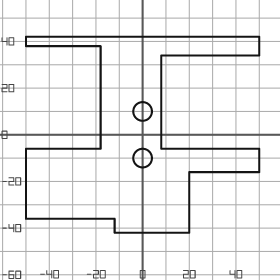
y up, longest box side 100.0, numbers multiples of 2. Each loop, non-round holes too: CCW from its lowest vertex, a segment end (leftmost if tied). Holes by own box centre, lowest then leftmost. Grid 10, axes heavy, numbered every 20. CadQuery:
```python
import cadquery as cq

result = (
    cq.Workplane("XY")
    .moveTo(-12.0, -42.0)
    .lineTo(20.0, -42.0)
    .lineTo(20.0, -16.0)
    .lineTo(50.0, -16.0)
    .lineTo(50.0, -6.0)
    .lineTo(8.0, -6.0)
    .lineTo(8.0, 34.0)
    .lineTo(50.0, 34.0)
    .lineTo(50.0, 42.0)
    .lineTo(-50.0, 42.0)
    .lineTo(-50.0, 38.0)
    .lineTo(-18.0, 38.0)
    .lineTo(-18.0, -6.0)
    .lineTo(-50.0, -6.0)
    .lineTo(-50.0, -36.0)
    .lineTo(-12.0, -36.0)
    .close()
    .moveTo(0.0, -10.0)
    .circle(4.0)
    .moveTo(0.0, 10.0)
    .circle(4.0)
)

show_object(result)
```